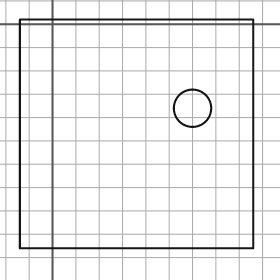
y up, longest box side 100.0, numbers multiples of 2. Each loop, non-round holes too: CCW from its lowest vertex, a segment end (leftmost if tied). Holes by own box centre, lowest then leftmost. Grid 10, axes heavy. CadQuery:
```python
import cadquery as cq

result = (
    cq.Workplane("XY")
    .moveTo(-14.0, -96.0)
    .lineTo(86.0, -96.0)
    .lineTo(86.0, 2.0)
    .lineTo(-14.0, 2.0)
    .close()
    .moveTo(60.0, -36.0)
    .circle(8.0)
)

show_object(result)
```